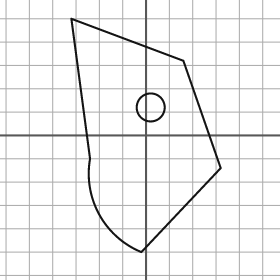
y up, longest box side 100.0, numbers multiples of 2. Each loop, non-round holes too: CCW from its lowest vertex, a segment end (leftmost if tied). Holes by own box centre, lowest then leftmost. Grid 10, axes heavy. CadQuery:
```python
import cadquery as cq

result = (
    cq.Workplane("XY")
    .moveTo(-2.0, -50.0)
    .lineTo(32.0, -14.0)
    .lineTo(16.0, 32.0)
    .lineTo(-32.0, 50.0)
    .lineTo(-24.0, -10.0)
    .threePointArc((-20.0, -34.0), (-2.0, -50.0))
    .close()
    .moveTo(2.0, 12.0)
    .circle(6.0)
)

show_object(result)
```